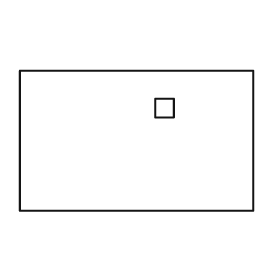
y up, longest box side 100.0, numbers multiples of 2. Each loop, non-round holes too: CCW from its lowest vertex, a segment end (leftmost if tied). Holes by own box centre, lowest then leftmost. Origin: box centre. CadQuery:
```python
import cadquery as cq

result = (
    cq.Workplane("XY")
    .moveTo(-50.0, -30.0)
    .lineTo(50.0, -30.0)
    .lineTo(50.0, 30.0)
    .lineTo(-50.0, 30.0)
    .close()
    .moveTo(8.0, 10.0)
    .lineTo(16.0, 10.0)
    .lineTo(16.0, 18.0)
    .lineTo(8.0, 18.0)
    .close()
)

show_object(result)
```